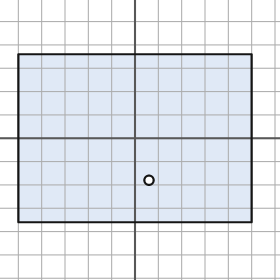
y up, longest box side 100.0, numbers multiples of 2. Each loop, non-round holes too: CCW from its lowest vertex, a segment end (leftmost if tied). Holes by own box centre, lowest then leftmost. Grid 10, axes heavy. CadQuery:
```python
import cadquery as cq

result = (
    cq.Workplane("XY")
    .moveTo(-50.0, -36.0)
    .lineTo(50.0, -36.0)
    .lineTo(50.0, 36.0)
    .lineTo(-50.0, 36.0)
    .close()
    .moveTo(6.0, -18.0)
    .circle(2.0)
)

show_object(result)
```